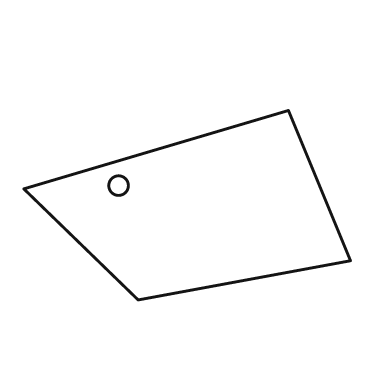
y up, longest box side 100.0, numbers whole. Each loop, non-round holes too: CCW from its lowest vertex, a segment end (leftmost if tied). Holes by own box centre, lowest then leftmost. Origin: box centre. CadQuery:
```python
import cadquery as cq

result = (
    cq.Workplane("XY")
    .moveTo(-15.0, -29.0)
    .lineTo(50.0, -17.0)
    .lineTo(31.0, 29.0)
    .lineTo(-50.0, 5.0)
    .close()
    .moveTo(-21.0, 6.0)
    .circle(3.0)
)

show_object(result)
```